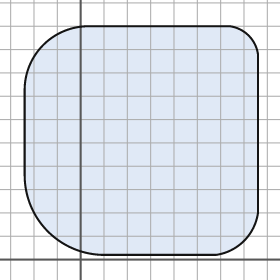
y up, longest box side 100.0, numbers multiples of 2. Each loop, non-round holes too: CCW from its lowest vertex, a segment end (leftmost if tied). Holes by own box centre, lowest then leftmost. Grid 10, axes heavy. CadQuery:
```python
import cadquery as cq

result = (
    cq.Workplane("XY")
    .moveTo(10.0, 2.0)
    .lineTo(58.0, 2.0)
    .threePointArc((70.0, 8.0), (76.0, 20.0))
    .lineTo(76.0, 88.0)
    .threePointArc((72.0, 96.0), (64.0, 100.0))
    .lineTo(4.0, 100.0)
    .threePointArc((-16.0, 92.0), (-24.0, 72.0))
    .lineTo(-24.0, 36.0)
    .threePointArc((-14.0, 12.0), (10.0, 2.0))
    .close()
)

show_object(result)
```